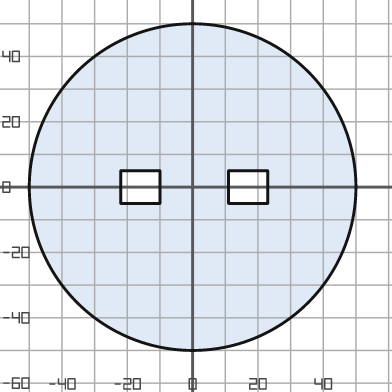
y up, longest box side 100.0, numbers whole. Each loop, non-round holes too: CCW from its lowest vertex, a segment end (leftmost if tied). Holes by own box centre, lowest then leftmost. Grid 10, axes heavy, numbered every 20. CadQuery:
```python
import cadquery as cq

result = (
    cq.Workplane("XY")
    .moveTo(0.0, 0.0)
    .circle(50.0)
    .moveTo(-22.0, -5.0)
    .lineTo(-10.0, -5.0)
    .lineTo(-10.0, 5.0)
    .lineTo(-22.0, 5.0)
    .close()
    .moveTo(11.0, -5.0)
    .lineTo(23.0, -5.0)
    .lineTo(23.0, 5.0)
    .lineTo(11.0, 5.0)
    .close()
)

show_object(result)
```